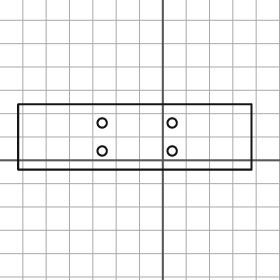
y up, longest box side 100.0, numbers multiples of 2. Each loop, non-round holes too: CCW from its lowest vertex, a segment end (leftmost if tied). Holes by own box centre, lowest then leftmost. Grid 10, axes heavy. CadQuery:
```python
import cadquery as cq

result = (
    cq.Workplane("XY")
    .moveTo(-62.0, -4.0)
    .lineTo(38.0, -4.0)
    .lineTo(38.0, 24.0)
    .lineTo(-62.0, 24.0)
    .close()
    .moveTo(-26.0, 4.0)
    .circle(2.0)
    .moveTo(4.0, 4.0)
    .circle(2.0)
    .moveTo(-26.0, 16.0)
    .circle(2.0)
    .moveTo(4.0, 16.0)
    .circle(2.0)
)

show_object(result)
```